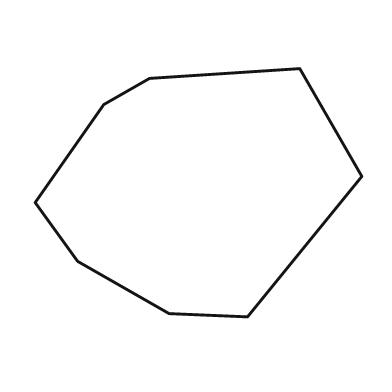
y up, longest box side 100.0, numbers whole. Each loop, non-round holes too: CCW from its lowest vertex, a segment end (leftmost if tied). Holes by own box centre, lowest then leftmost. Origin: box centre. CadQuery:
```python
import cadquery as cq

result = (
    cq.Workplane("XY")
    .moveTo(15.0, -38.0)
    .lineTo(50.0, 5.0)
    .lineTo(31.0, 38.0)
    .lineTo(-15.0, 35.0)
    .lineTo(-29.0, 27.0)
    .lineTo(-50.0, -3.0)
    .lineTo(-37.0, -21.0)
    .lineTo(-9.0, -37.0)
    .close()
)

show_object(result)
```